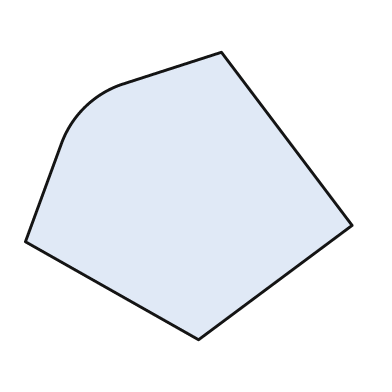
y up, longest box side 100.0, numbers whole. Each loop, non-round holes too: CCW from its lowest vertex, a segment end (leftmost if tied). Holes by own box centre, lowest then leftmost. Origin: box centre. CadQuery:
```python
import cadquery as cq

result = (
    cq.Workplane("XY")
    .moveTo(3.0, -44.0)
    .lineTo(50.0, -9.0)
    .lineTo(10.0, 44.0)
    .lineTo(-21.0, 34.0)
    .threePointArc((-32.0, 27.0), (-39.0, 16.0))
    .lineTo(-50.0, -14.0)
    .close()
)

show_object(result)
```